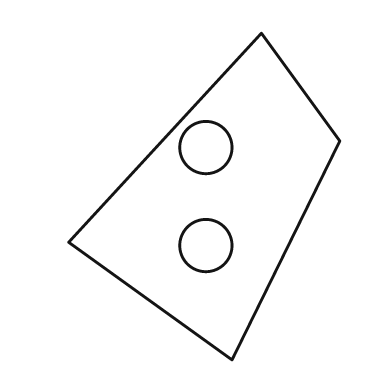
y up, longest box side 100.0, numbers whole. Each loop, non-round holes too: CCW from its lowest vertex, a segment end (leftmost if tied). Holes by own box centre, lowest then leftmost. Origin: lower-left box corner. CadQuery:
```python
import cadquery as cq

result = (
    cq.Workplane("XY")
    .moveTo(50.0, 0.0)
    .lineTo(83.0, 67.0)
    .lineTo(59.0, 100.0)
    .lineTo(0.0, 36.0)
    .close()
    .moveTo(42.0, 35.0)
    .circle(8.0)
    .moveTo(42.0, 65.0)
    .circle(8.0)
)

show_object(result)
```